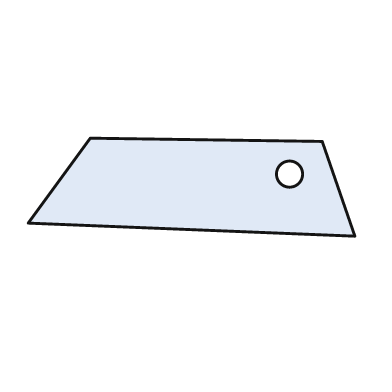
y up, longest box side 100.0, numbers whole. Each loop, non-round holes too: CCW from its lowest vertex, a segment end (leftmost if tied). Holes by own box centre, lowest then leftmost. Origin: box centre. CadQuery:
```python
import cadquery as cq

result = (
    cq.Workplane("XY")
    .moveTo(50.0, -15.0)
    .lineTo(40.0, 14.0)
    .lineTo(-31.0, 15.0)
    .lineTo(-50.0, -11.0)
    .close()
    .moveTo(30.0, 4.0)
    .circle(4.0)
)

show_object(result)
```